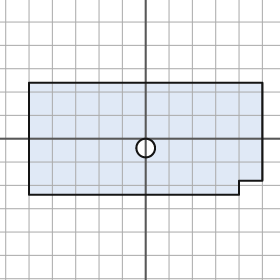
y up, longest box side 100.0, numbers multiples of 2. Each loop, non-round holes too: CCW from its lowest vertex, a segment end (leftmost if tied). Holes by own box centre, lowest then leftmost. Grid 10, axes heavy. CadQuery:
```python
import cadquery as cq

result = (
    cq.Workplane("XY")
    .moveTo(-50.0, -24.0)
    .lineTo(40.0, -24.0)
    .lineTo(40.0, -18.0)
    .lineTo(50.0, -18.0)
    .lineTo(50.0, 24.0)
    .lineTo(-50.0, 24.0)
    .close()
    .moveTo(0.0, -4.0)
    .circle(4.0)
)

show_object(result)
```